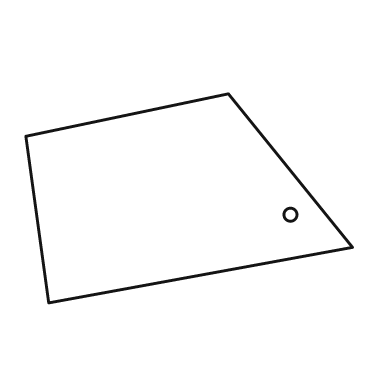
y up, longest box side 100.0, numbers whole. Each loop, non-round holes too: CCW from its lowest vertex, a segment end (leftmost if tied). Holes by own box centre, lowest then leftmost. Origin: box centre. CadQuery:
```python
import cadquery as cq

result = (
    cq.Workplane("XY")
    .moveTo(-43.0, -32.0)
    .lineTo(50.0, -15.0)
    .lineTo(12.0, 32.0)
    .lineTo(-50.0, 19.0)
    .close()
    .moveTo(31.0, -5.0)
    .circle(2.0)
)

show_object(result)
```